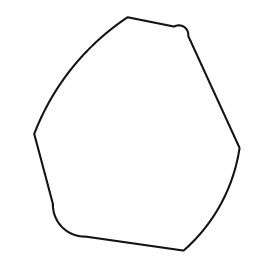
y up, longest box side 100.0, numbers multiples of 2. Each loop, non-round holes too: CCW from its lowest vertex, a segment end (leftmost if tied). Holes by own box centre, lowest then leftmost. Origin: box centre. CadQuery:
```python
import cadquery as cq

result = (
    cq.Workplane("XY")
    .moveTo(20.0, -50.0)
    .threePointArc((36.0, -30.0), (44.0, -6.0))
    .lineTo(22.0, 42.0)
    .threePointArc((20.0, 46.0), (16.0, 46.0))
    .lineTo(-4.0, 50.0)
    .threePointArc((-28.0, 28.0), (-44.0, 0.0))
    .lineTo(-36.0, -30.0)
    .threePointArc((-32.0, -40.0), (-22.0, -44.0))
    .close()
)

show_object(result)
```